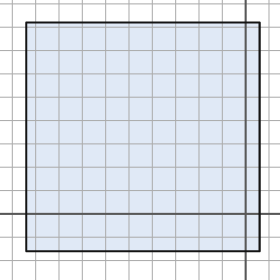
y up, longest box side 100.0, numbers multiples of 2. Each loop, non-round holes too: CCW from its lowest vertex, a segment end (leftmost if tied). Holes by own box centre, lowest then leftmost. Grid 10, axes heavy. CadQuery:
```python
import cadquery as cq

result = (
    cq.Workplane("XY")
    .moveTo(-94.0, -16.0)
    .lineTo(6.0, -16.0)
    .lineTo(6.0, 82.0)
    .lineTo(-94.0, 82.0)
    .close()
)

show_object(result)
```